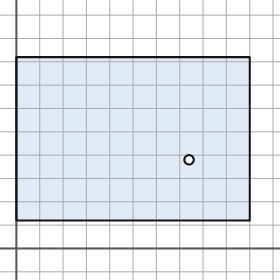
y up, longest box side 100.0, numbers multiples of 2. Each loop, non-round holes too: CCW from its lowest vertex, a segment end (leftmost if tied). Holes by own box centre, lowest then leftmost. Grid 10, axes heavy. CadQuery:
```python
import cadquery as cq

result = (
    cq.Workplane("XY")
    .moveTo(0.0, 12.0)
    .lineTo(100.0, 12.0)
    .lineTo(100.0, 82.0)
    .lineTo(0.0, 82.0)
    .close()
    .moveTo(74.0, 38.0)
    .circle(2.0)
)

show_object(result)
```